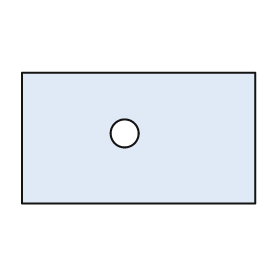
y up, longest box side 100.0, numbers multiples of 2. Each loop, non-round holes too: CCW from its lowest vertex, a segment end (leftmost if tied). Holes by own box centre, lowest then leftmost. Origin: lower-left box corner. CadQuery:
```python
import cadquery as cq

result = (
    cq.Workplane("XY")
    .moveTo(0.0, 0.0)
    .lineTo(100.0, 0.0)
    .lineTo(100.0, 56.0)
    .lineTo(0.0, 56.0)
    .close()
    .moveTo(44.0, 30.0)
    .circle(6.0)
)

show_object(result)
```